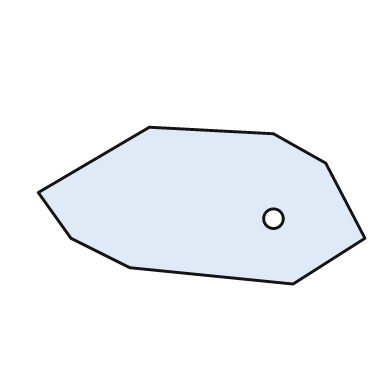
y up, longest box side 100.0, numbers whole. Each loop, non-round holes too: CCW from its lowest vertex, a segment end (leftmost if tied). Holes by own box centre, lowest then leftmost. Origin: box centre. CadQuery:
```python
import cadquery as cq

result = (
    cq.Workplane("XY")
    .moveTo(28.0, -24.0)
    .lineTo(50.0, -10.0)
    .lineTo(38.0, 13.0)
    .lineTo(22.0, 22.0)
    .lineTo(-16.0, 24.0)
    .lineTo(-50.0, 4.0)
    .lineTo(-40.0, -10.0)
    .lineTo(-22.0, -19.0)
    .close()
    .moveTo(22.0, -4.0)
    .circle(3.0)
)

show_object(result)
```